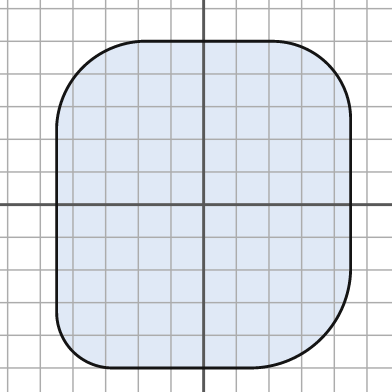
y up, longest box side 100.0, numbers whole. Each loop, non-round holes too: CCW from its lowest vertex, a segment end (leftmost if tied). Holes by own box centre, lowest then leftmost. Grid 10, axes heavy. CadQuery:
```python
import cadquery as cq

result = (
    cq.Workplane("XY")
    .moveTo(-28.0, -50.0)
    .lineTo(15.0, -50.0)
    .threePointArc((36.0, -41.0), (45.0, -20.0))
    .lineTo(45.0, 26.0)
    .threePointArc((38.0, 43.0), (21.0, 50.0))
    .lineTo(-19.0, 50.0)
    .threePointArc((-37.0, 42.0), (-45.0, 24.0))
    .lineTo(-45.0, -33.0)
    .threePointArc((-40.0, -45.0), (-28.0, -50.0))
    .close()
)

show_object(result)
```